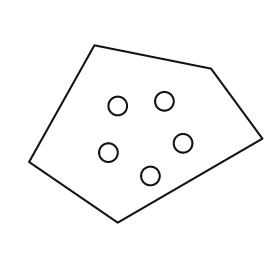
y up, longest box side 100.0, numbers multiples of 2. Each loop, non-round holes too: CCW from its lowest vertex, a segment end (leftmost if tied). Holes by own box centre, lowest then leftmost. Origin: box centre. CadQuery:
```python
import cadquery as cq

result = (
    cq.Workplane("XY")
    .moveTo(-12.0, -38.0)
    .lineTo(50.0, -2.0)
    .lineTo(28.0, 28.0)
    .lineTo(-22.0, 38.0)
    .lineTo(-50.0, -12.0)
    .close()
    .moveTo(2.0, -18.0)
    .circle(4.0)
    .moveTo(-16.0, -8.0)
    .circle(4.0)
    .moveTo(16.0, -4.0)
    .circle(4.0)
    .moveTo(-12.0, 12.0)
    .circle(4.0)
    .moveTo(8.0, 14.0)
    .circle(4.0)
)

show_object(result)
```